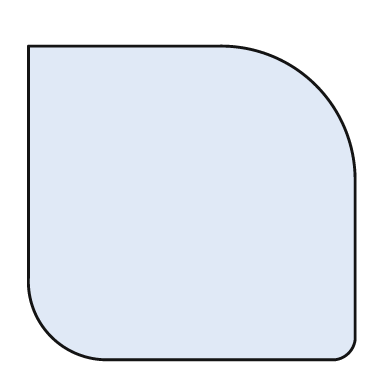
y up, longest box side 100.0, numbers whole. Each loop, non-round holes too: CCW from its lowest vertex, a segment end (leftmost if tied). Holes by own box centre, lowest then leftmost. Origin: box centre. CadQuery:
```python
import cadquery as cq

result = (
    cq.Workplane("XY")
    .moveTo(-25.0, -48.0)
    .lineTo(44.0, -48.0)
    .threePointArc((48.0, -46.0), (50.0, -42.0))
    .lineTo(50.0, 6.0)
    .threePointArc((38.0, 36.0), (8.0, 48.0))
    .lineTo(-50.0, 48.0)
    .lineTo(-50.0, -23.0)
    .threePointArc((-43.0, -41.0), (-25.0, -48.0))
    .close()
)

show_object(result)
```